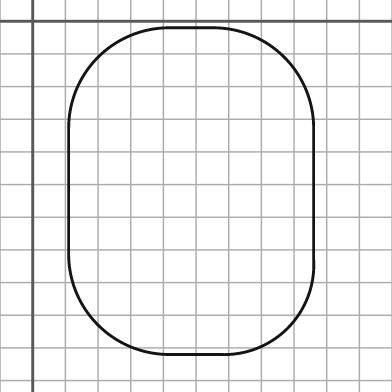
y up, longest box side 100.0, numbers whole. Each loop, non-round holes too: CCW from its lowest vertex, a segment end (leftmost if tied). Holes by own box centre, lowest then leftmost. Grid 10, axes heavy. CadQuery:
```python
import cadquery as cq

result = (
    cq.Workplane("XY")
    .moveTo(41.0, -102.0)
    .lineTo(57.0, -102.0)
    .threePointArc((78.0, -94.0), (86.0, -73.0))
    .lineTo(86.0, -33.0)
    .threePointArc((77.0, -11.0), (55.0, -2.0))
    .lineTo(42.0, -2.0)
    .threePointArc((20.0, -11.0), (11.0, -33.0))
    .lineTo(11.0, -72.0)
    .threePointArc((20.0, -93.0), (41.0, -102.0))
    .close()
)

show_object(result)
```